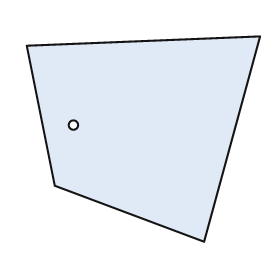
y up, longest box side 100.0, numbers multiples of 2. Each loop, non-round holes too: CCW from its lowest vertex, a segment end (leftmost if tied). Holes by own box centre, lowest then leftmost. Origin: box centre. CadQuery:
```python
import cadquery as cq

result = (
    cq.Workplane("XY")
    .moveTo(26.0, -44.0)
    .lineTo(50.0, 44.0)
    .lineTo(-50.0, 40.0)
    .lineTo(-38.0, -20.0)
    .close()
    .moveTo(-30.0, 6.0)
    .circle(2.0)
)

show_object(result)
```